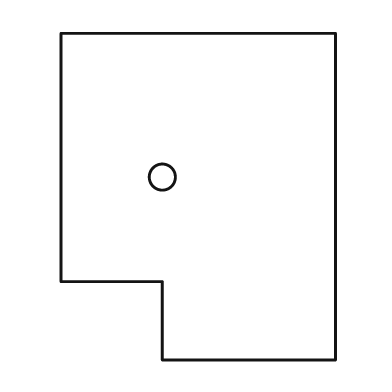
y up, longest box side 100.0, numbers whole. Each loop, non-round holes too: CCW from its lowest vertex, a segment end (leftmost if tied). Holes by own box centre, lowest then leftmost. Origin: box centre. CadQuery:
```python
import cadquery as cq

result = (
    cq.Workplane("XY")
    .moveTo(-11.0, -50.0)
    .lineTo(42.0, -50.0)
    .lineTo(42.0, 50.0)
    .lineTo(-42.0, 50.0)
    .lineTo(-42.0, -26.0)
    .lineTo(-11.0, -26.0)
    .close()
    .moveTo(-11.0, 6.0)
    .circle(4.0)
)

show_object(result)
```